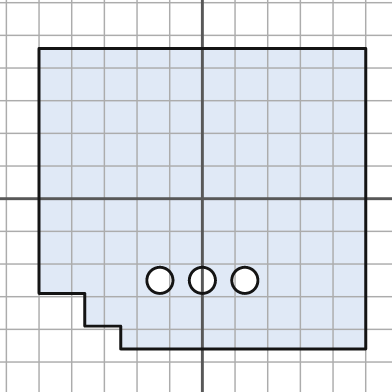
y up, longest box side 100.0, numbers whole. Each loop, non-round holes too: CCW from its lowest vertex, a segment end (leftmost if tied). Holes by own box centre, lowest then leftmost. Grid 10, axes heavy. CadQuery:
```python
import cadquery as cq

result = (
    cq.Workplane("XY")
    .moveTo(-25.0, -46.0)
    .lineTo(50.0, -46.0)
    .lineTo(50.0, 46.0)
    .lineTo(-50.0, 46.0)
    .lineTo(-50.0, -29.0)
    .lineTo(-36.0, -29.0)
    .lineTo(-36.0, -39.0)
    .lineTo(-25.0, -39.0)
    .close()
    .moveTo(-13.0, -25.0)
    .circle(4.0)
    .moveTo(0.0, -25.0)
    .circle(4.0)
    .moveTo(13.0, -25.0)
    .circle(4.0)
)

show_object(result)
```